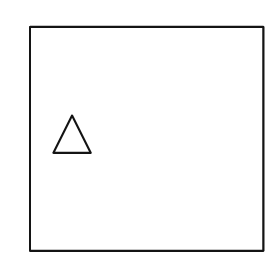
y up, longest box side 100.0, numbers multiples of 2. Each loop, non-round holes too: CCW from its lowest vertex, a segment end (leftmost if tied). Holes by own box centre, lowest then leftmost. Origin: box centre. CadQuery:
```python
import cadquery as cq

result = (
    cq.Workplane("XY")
    .moveTo(-50.0, -48.0)
    .lineTo(50.0, -48.0)
    .lineTo(50.0, 48.0)
    .lineTo(-50.0, 48.0)
    .close()
    .moveTo(-40.0, -6.0)
    .lineTo(-24.0, -6.0)
    .lineTo(-32.0, 10.0)
    .close()
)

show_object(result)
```